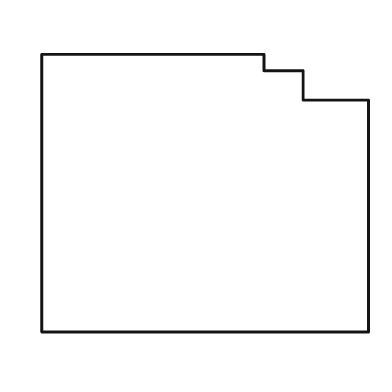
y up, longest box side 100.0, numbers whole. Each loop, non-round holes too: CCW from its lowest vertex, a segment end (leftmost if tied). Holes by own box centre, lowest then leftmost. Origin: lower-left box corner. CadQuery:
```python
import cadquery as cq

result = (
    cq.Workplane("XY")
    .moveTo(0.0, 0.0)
    .lineTo(100.0, 0.0)
    .lineTo(100.0, 71.0)
    .lineTo(80.0, 71.0)
    .lineTo(80.0, 80.0)
    .lineTo(68.0, 80.0)
    .lineTo(68.0, 85.0)
    .lineTo(0.0, 85.0)
    .close()
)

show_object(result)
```